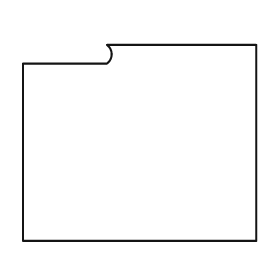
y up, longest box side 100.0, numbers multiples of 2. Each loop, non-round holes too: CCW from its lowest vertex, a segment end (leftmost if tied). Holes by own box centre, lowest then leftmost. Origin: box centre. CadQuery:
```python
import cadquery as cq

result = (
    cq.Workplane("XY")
    .moveTo(-50.0, -42.0)
    .lineTo(50.0, -42.0)
    .lineTo(50.0, 42.0)
    .lineTo(-14.0, 42.0)
    .threePointArc((-12.0, 38.0), (-14.0, 34.0))
    .lineTo(-50.0, 34.0)
    .close()
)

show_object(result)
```